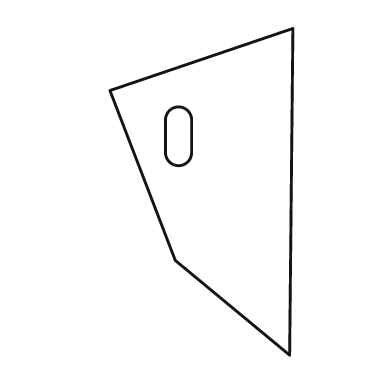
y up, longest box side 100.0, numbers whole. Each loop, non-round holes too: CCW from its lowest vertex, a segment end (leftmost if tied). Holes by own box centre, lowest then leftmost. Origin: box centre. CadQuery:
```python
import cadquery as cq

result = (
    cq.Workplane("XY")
    .moveTo(27.0, -50.0)
    .lineTo(28.0, 50.0)
    .lineTo(-28.0, 31.0)
    .lineTo(-8.0, -21.0)
    .close()
    .moveTo(-11.0, 12.0)
    .threePointArc((-7.0, 8.0), (-3.0, 12.0))
    .lineTo(-3.0, 22.0)
    .threePointArc((-7.0, 26.0), (-11.0, 22.0))
    .close()
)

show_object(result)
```